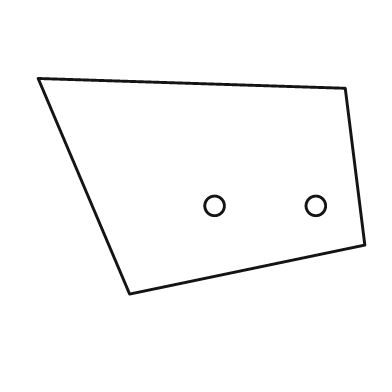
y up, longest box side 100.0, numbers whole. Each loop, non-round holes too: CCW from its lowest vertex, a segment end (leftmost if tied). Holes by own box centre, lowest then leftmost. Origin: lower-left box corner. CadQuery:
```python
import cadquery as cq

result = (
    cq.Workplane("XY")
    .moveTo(28.0, 0.0)
    .lineTo(100.0, 15.0)
    .lineTo(94.0, 63.0)
    .lineTo(0.0, 66.0)
    .close()
    .moveTo(54.0, 27.0)
    .circle(3.0)
    .moveTo(85.0, 27.0)
    .circle(3.0)
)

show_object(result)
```